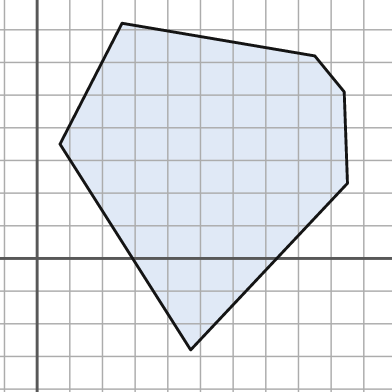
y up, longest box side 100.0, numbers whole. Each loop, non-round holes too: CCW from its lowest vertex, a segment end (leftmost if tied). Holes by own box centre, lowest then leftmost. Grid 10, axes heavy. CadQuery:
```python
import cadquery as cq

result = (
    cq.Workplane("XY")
    .moveTo(47.0, -28.0)
    .lineTo(95.0, 23.0)
    .lineTo(94.0, 51.0)
    .lineTo(85.0, 62.0)
    .lineTo(26.0, 72.0)
    .lineTo(7.0, 35.0)
    .close()
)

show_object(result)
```